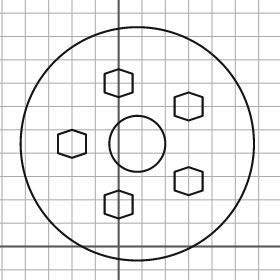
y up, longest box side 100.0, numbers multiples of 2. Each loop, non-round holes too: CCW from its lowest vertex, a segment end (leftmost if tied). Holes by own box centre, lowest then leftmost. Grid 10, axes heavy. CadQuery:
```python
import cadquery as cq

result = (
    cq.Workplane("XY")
    .moveTo(8.0, 44.0)
    .circle(50.0)
    .moveTo(0.0, 12.0)
    .lineTo(6.0, 14.0)
    .lineTo(6.0, 22.0)
    .lineTo(0.0, 24.0)
    .lineTo(-6.0, 22.0)
    .lineTo(-6.0, 14.0)
    .close()
    .moveTo(30.0, 22.0)
    .lineTo(36.0, 24.0)
    .lineTo(36.0, 32.0)
    .lineTo(30.0, 34.0)
    .lineTo(24.0, 32.0)
    .lineTo(24.0, 24.0)
    .close()
    .moveTo(-20.0, 38.0)
    .lineTo(-14.0, 40.0)
    .lineTo(-14.0, 48.0)
    .lineTo(-20.0, 50.0)
    .lineTo(-26.0, 48.0)
    .lineTo(-26.0, 40.0)
    .close()
    .moveTo(8.0, 44.0)
    .circle(12.0)
    .moveTo(30.0, 54.0)
    .lineTo(36.0, 56.0)
    .lineTo(36.0, 64.0)
    .lineTo(30.0, 66.0)
    .lineTo(24.0, 64.0)
    .lineTo(24.0, 56.0)
    .close()
    .moveTo(0.0, 64.0)
    .lineTo(6.0, 66.0)
    .lineTo(6.0, 74.0)
    .lineTo(0.0, 76.0)
    .lineTo(-6.0, 74.0)
    .lineTo(-6.0, 66.0)
    .close()
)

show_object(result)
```